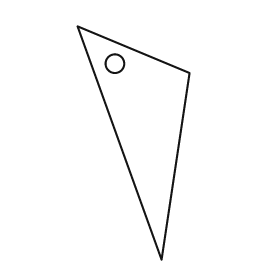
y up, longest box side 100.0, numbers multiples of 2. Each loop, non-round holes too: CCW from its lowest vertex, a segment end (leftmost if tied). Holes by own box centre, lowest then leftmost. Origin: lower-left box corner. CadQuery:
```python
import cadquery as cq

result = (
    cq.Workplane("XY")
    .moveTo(36.0, 0.0)
    .lineTo(48.0, 80.0)
    .lineTo(0.0, 100.0)
    .close()
    .moveTo(16.0, 84.0)
    .circle(4.0)
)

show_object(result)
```